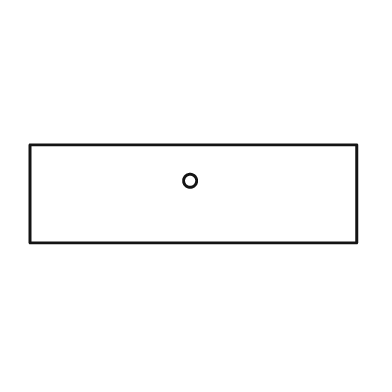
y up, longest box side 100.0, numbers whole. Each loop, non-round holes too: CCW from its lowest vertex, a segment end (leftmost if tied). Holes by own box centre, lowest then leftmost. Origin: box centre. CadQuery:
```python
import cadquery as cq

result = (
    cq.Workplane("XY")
    .moveTo(-50.0, -15.0)
    .lineTo(50.0, -15.0)
    .lineTo(50.0, 15.0)
    .lineTo(-50.0, 15.0)
    .close()
    .moveTo(-1.0, 4.0)
    .circle(2.0)
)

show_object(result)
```